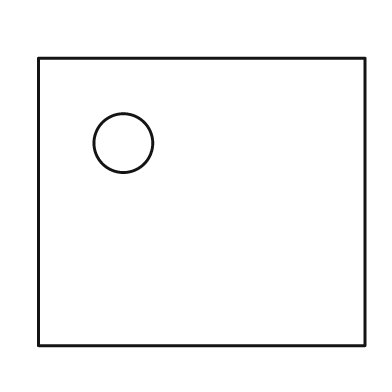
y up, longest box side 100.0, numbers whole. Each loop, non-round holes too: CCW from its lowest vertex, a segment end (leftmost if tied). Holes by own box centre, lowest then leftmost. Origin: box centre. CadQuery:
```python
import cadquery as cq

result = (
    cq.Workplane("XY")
    .moveTo(-50.0, -44.0)
    .lineTo(50.0, -44.0)
    .lineTo(50.0, 44.0)
    .lineTo(-50.0, 44.0)
    .close()
    .moveTo(-24.0, 18.0)
    .circle(9.0)
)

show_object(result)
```